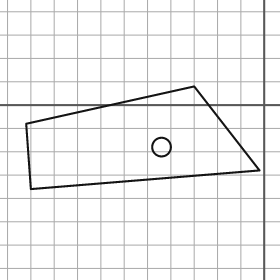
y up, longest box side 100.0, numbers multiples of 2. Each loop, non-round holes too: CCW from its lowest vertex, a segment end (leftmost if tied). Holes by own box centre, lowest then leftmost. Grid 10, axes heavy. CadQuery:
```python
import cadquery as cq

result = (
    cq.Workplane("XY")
    .moveTo(-100.0, -36.0)
    .lineTo(-2.0, -28.0)
    .lineTo(-30.0, 8.0)
    .lineTo(-102.0, -8.0)
    .close()
    .moveTo(-44.0, -18.0)
    .circle(4.0)
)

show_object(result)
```